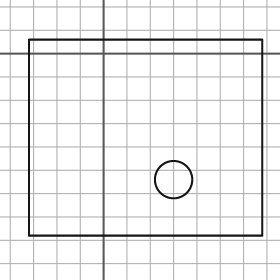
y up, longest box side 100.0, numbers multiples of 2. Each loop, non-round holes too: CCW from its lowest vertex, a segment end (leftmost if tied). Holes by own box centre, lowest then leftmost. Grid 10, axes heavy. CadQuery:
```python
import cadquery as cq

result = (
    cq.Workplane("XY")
    .moveTo(-32.0, -78.0)
    .lineTo(68.0, -78.0)
    .lineTo(68.0, 6.0)
    .lineTo(-32.0, 6.0)
    .close()
    .moveTo(30.0, -54.0)
    .circle(8.0)
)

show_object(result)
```